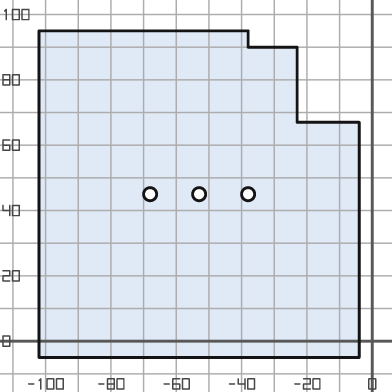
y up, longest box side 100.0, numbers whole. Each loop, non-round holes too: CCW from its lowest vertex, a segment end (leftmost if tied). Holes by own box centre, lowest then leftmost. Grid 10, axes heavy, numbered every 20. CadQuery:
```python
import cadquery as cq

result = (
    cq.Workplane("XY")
    .moveTo(-102.0, -5.0)
    .lineTo(-4.0, -5.0)
    .lineTo(-4.0, 67.0)
    .lineTo(-23.0, 67.0)
    .lineTo(-23.0, 90.0)
    .lineTo(-38.0, 90.0)
    .lineTo(-38.0, 95.0)
    .lineTo(-102.0, 95.0)
    .close()
    .moveTo(-68.0, 45.0)
    .circle(2.0)
    .moveTo(-53.0, 45.0)
    .circle(2.0)
    .moveTo(-38.0, 45.0)
    .circle(2.0)
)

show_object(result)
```